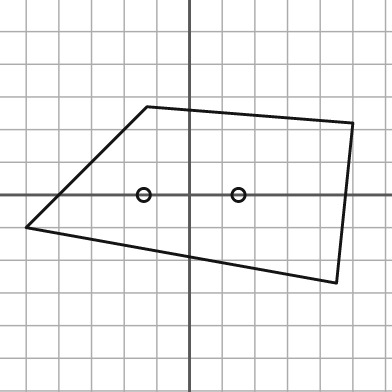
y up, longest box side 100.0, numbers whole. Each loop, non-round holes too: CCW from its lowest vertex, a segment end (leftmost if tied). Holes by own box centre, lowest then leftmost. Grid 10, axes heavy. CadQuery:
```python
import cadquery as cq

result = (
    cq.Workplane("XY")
    .moveTo(45.0, -27.0)
    .lineTo(50.0, 22.0)
    .lineTo(-13.0, 27.0)
    .lineTo(-50.0, -10.0)
    .close()
    .moveTo(-14.0, 0.0)
    .circle(2.0)
    .moveTo(15.0, 0.0)
    .circle(2.0)
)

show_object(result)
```